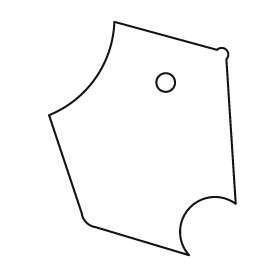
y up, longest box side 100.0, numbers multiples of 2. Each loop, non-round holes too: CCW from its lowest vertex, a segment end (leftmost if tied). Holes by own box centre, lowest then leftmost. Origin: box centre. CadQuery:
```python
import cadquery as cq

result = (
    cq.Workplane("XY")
    .moveTo(20.0, -50.0)
    .threePointArc((20.0, -30.0), (40.0, -28.0))
    .lineTo(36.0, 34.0)
    .threePointArc((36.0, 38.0), (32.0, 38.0))
    .lineTo(-12.0, 50.0)
    .threePointArc((-20.0, 26.0), (-40.0, 10.0))
    .lineTo(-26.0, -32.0)
    .threePointArc((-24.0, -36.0), (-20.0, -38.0))
    .close()
    .moveTo(10.0, 24.0)
    .circle(4.0)
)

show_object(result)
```